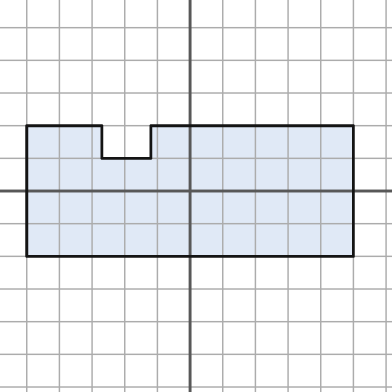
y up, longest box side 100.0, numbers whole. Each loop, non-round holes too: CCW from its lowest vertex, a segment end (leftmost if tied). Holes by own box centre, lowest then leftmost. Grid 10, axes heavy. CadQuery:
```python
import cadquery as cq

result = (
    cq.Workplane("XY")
    .moveTo(-50.0, -20.0)
    .lineTo(50.0, -20.0)
    .lineTo(50.0, 20.0)
    .lineTo(-12.0, 20.0)
    .lineTo(-12.0, 10.0)
    .lineTo(-27.0, 10.0)
    .lineTo(-27.0, 20.0)
    .lineTo(-50.0, 20.0)
    .close()
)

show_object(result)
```